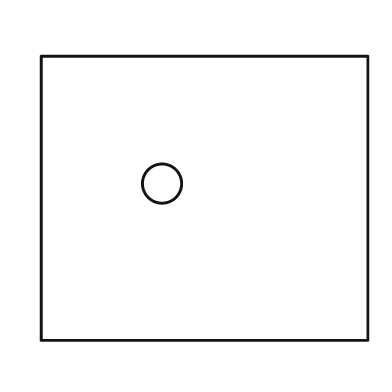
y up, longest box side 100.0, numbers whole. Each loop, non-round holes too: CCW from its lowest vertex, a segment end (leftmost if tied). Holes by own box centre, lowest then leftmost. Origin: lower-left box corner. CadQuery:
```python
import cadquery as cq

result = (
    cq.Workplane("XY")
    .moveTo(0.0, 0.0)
    .lineTo(100.0, 0.0)
    .lineTo(100.0, 87.0)
    .lineTo(0.0, 87.0)
    .close()
    .moveTo(37.0, 48.0)
    .circle(6.0)
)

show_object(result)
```